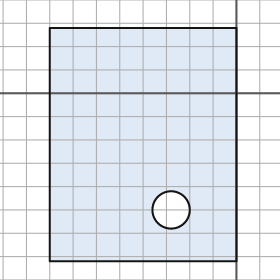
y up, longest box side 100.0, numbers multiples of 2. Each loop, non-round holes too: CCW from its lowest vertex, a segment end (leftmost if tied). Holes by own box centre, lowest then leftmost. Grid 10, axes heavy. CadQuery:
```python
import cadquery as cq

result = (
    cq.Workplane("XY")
    .moveTo(-80.0, -72.0)
    .lineTo(0.0, -72.0)
    .lineTo(0.0, 28.0)
    .lineTo(-80.0, 28.0)
    .close()
    .moveTo(-28.0, -50.0)
    .circle(8.0)
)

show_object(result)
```